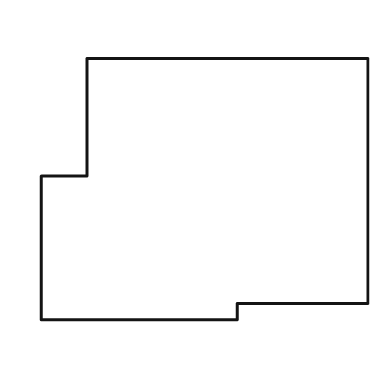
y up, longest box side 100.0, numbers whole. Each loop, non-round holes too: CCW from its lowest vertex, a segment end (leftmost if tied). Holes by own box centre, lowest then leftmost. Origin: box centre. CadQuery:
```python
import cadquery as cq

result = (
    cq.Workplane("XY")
    .moveTo(-50.0, -40.0)
    .lineTo(10.0, -40.0)
    .lineTo(10.0, -35.0)
    .lineTo(50.0, -35.0)
    .lineTo(50.0, 40.0)
    .lineTo(-36.0, 40.0)
    .lineTo(-36.0, 4.0)
    .lineTo(-50.0, 4.0)
    .close()
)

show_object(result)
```